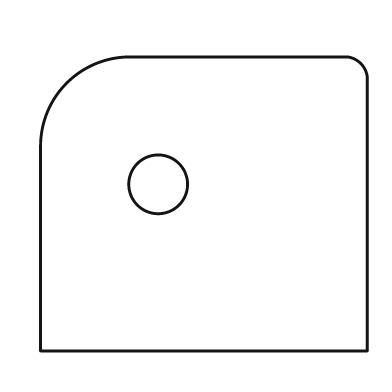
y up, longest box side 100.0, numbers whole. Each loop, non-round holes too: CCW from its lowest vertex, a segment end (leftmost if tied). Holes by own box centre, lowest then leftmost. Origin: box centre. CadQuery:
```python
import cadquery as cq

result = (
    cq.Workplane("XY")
    .moveTo(-50.0, -45.0)
    .lineTo(50.0, -45.0)
    .lineTo(50.0, 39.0)
    .threePointArc((48.0, 43.0), (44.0, 45.0))
    .lineTo(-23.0, 45.0)
    .threePointArc((-42.0, 37.0), (-50.0, 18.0))
    .close()
    .moveTo(-14.0, 6.0)
    .circle(9.0)
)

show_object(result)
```